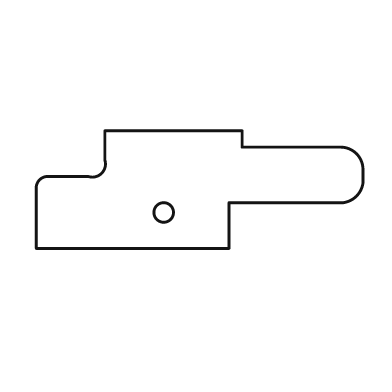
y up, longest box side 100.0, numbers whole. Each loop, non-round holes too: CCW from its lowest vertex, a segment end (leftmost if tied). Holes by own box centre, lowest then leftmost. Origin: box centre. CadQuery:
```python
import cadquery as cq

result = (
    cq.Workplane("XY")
    .moveTo(-50.0, -18.0)
    .lineTo(9.0, -18.0)
    .lineTo(9.0, -4.0)
    .lineTo(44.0, -4.0)
    .threePointArc((48.0, -2.0), (50.0, 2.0))
    .lineTo(50.0, 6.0)
    .threePointArc((48.0, 11.0), (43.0, 13.0))
    .lineTo(13.0, 13.0)
    .lineTo(13.0, 18.0)
    .lineTo(-29.0, 18.0)
    .lineTo(-29.0, 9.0)
    .threePointArc((-30.0, 5.0), (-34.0, 4.0))
    .lineTo(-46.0, 4.0)
    .threePointArc((-49.0, 3.0), (-50.0, 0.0))
    .close()
    .moveTo(-11.0, -7.0)
    .circle(3.0)
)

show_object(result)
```